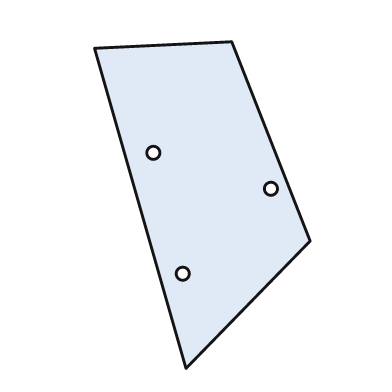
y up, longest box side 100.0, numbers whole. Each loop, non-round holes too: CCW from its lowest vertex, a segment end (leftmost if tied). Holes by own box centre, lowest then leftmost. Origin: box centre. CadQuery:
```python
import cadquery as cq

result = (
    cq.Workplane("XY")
    .moveTo(-5.0, -50.0)
    .lineTo(33.0, -11.0)
    .lineTo(9.0, 50.0)
    .lineTo(-33.0, 48.0)
    .close()
    .moveTo(-6.0, -21.0)
    .circle(2.0)
    .moveTo(21.0, 5.0)
    .circle(2.0)
    .moveTo(-15.0, 16.0)
    .circle(2.0)
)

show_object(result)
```